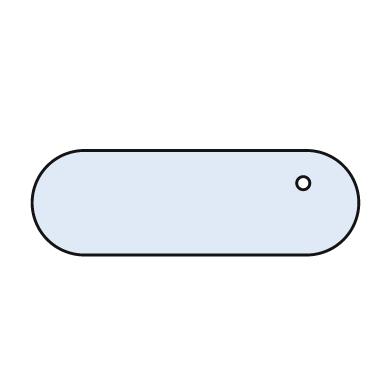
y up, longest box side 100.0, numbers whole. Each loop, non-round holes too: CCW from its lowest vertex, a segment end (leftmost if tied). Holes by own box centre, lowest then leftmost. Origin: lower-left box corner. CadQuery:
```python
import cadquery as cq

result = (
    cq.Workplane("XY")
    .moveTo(16.0, 0.0)
    .lineTo(84.0, 0.0)
    .threePointArc((100.0, 16.0), (84.0, 32.0))
    .lineTo(16.0, 32.0)
    .threePointArc((0.0, 16.0), (16.0, 0.0))
    .close()
    .moveTo(83.0, 22.0)
    .circle(2.0)
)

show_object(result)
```